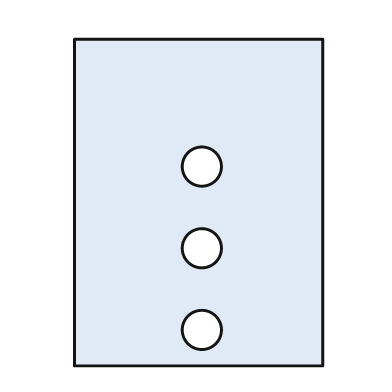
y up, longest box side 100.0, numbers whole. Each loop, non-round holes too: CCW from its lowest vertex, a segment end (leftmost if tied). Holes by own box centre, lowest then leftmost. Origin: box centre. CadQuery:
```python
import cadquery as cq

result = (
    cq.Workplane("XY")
    .moveTo(-38.0, -50.0)
    .lineTo(38.0, -50.0)
    .lineTo(38.0, 50.0)
    .lineTo(-38.0, 50.0)
    .close()
    .moveTo(1.0, -39.0)
    .circle(6.0)
    .moveTo(1.0, -14.0)
    .circle(6.0)
    .moveTo(1.0, 11.0)
    .circle(6.0)
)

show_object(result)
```